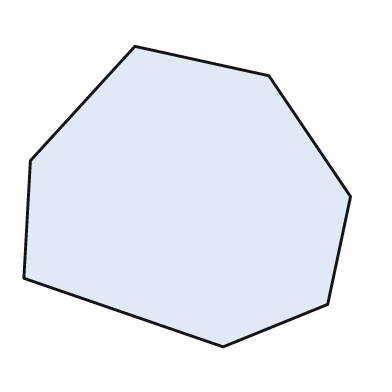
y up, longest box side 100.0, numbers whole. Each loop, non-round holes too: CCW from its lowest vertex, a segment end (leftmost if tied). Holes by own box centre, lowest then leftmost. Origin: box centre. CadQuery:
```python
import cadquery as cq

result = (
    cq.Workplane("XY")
    .moveTo(11.0, -46.0)
    .lineTo(43.0, -33.0)
    .lineTo(50.0, 0.0)
    .lineTo(25.0, 37.0)
    .lineTo(-16.0, 46.0)
    .lineTo(-48.0, 11.0)
    .lineTo(-50.0, -25.0)
    .close()
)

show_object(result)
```